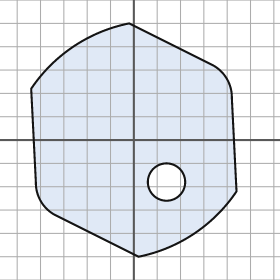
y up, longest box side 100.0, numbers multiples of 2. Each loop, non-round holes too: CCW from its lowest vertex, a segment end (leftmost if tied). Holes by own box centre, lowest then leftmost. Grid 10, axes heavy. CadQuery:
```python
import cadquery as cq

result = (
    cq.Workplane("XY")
    .moveTo(2.0, -50.0)
    .threePointArc((26.0, -40.0), (44.0, -22.0))
    .lineTo(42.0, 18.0)
    .threePointArc((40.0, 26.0), (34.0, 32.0))
    .lineTo(-2.0, 50.0)
    .threePointArc((-26.0, 40.0), (-44.0, 22.0))
    .lineTo(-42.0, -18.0)
    .threePointArc((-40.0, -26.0), (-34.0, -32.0))
    .close()
    .moveTo(14.0, -18.0)
    .circle(8.0)
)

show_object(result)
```